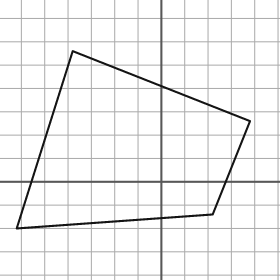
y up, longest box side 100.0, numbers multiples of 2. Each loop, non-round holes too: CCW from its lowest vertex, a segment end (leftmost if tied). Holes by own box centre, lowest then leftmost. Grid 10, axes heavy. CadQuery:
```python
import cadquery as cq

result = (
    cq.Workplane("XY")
    .moveTo(-62.0, -20.0)
    .lineTo(22.0, -14.0)
    .lineTo(38.0, 26.0)
    .lineTo(-38.0, 56.0)
    .close()
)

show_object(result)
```